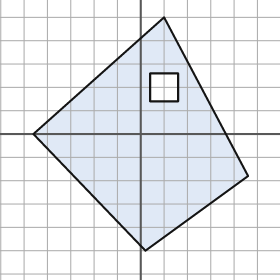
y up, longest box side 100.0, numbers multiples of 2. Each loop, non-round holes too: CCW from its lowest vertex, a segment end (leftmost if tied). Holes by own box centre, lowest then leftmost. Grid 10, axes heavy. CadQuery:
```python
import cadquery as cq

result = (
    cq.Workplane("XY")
    .moveTo(2.0, -50.0)
    .lineTo(46.0, -18.0)
    .lineTo(10.0, 50.0)
    .lineTo(-46.0, 0.0)
    .close()
    .moveTo(4.0, 14.0)
    .lineTo(16.0, 14.0)
    .lineTo(16.0, 26.0)
    .lineTo(4.0, 26.0)
    .close()
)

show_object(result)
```